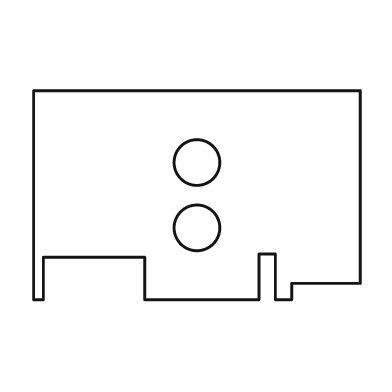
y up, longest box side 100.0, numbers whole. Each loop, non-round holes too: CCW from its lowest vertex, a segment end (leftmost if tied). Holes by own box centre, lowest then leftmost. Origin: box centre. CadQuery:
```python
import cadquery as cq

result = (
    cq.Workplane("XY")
    .moveTo(-50.0, -32.0)
    .lineTo(-47.0, -32.0)
    .lineTo(-47.0, -19.0)
    .lineTo(-16.0, -19.0)
    .lineTo(-16.0, -32.0)
    .lineTo(19.0, -32.0)
    .lineTo(19.0, -18.0)
    .lineTo(24.0, -18.0)
    .lineTo(24.0, -32.0)
    .lineTo(29.0, -32.0)
    .lineTo(29.0, -27.0)
    .lineTo(50.0, -27.0)
    .lineTo(50.0, 32.0)
    .lineTo(-50.0, 32.0)
    .close()
    .moveTo(0.0, -10.0)
    .circle(7.0)
    .moveTo(0.0, 10.0)
    .circle(7.0)
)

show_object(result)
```